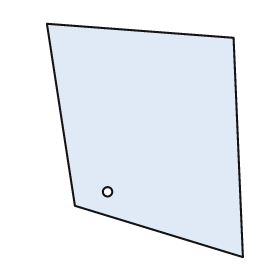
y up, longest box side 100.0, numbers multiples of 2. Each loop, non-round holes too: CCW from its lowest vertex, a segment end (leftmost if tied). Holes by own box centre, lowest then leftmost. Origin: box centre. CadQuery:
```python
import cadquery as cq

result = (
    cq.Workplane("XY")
    .moveTo(42.0, -50.0)
    .lineTo(38.0, 44.0)
    .lineTo(-42.0, 50.0)
    .lineTo(-30.0, -28.0)
    .close()
    .moveTo(-16.0, -22.0)
    .circle(2.0)
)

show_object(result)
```